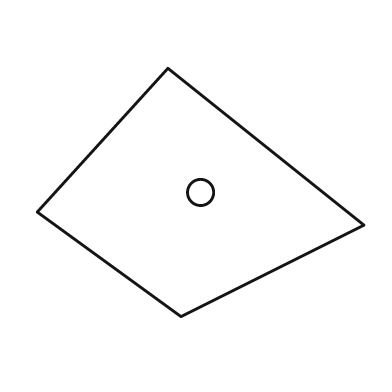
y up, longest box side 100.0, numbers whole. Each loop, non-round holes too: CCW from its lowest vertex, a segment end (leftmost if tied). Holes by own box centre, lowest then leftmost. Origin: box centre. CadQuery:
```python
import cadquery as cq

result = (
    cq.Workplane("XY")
    .moveTo(-6.0, -38.0)
    .lineTo(50.0, -10.0)
    .lineTo(-10.0, 38.0)
    .lineTo(-50.0, -6.0)
    .close()
    .moveTo(0.0, 0.0)
    .circle(4.0)
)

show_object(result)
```